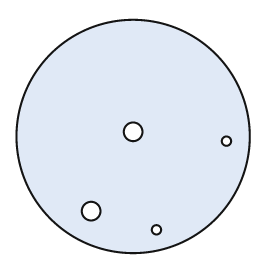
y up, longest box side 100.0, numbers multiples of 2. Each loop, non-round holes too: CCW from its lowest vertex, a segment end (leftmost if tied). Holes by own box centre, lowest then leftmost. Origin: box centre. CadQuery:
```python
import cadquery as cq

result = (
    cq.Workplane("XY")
    .moveTo(0.0, 0.0)
    .circle(50.0)
    .moveTo(10.0, -40.0)
    .circle(2.0)
    .moveTo(-18.0, -32.0)
    .circle(4.0)
    .moveTo(40.0, -2.0)
    .circle(2.0)
    .moveTo(0.0, 2.0)
    .circle(4.0)
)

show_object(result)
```